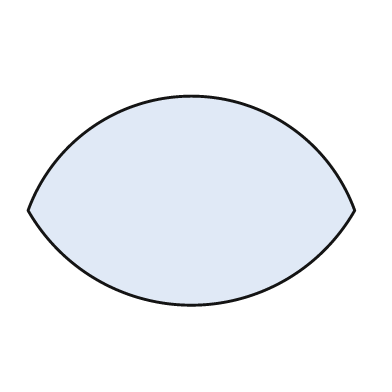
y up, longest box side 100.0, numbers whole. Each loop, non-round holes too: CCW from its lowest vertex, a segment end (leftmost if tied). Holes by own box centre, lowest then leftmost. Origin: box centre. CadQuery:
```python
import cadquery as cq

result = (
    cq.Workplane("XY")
    .moveTo(-50.0, -3.0)
    .threePointArc((0.0, -32.0), (50.0, -3.0))
    .threePointArc((0.0, 32.0), (-50.0, -3.0))
    .close()
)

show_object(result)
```